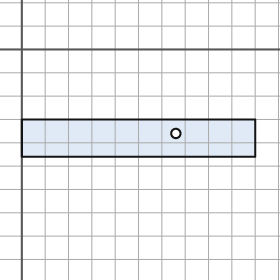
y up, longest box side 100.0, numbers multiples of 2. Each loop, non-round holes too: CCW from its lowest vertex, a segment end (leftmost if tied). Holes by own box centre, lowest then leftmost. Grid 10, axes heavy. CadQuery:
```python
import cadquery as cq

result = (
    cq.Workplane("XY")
    .moveTo(0.0, -46.0)
    .lineTo(100.0, -46.0)
    .lineTo(100.0, -30.0)
    .lineTo(0.0, -30.0)
    .close()
    .moveTo(66.0, -36.0)
    .circle(2.0)
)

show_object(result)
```